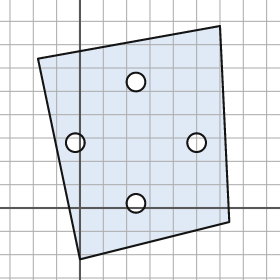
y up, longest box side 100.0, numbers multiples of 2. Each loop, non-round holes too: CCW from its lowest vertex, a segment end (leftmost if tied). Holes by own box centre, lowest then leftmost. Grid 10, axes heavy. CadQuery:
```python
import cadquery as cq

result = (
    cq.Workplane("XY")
    .moveTo(0.0, -22.0)
    .lineTo(64.0, -6.0)
    .lineTo(60.0, 78.0)
    .lineTo(-18.0, 64.0)
    .close()
    .moveTo(24.0, 2.0)
    .circle(4.0)
    .moveTo(-2.0, 28.0)
    .circle(4.0)
    .moveTo(50.0, 28.0)
    .circle(4.0)
    .moveTo(24.0, 54.0)
    .circle(4.0)
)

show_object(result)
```